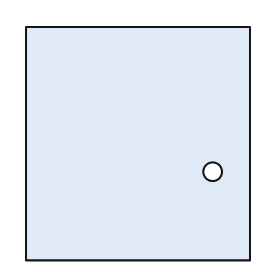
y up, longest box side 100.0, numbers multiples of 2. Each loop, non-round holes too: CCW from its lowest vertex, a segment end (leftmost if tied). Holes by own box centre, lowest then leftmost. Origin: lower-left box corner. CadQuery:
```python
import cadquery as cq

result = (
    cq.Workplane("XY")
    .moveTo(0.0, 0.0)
    .lineTo(96.0, 0.0)
    .lineTo(96.0, 100.0)
    .lineTo(0.0, 100.0)
    .close()
    .moveTo(80.0, 38.0)
    .circle(4.0)
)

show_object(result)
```